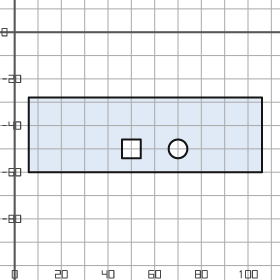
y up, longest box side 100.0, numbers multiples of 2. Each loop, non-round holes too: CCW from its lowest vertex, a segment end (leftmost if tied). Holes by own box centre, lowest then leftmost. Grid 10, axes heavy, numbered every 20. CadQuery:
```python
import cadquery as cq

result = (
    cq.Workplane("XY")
    .moveTo(6.0, -60.0)
    .lineTo(106.0, -60.0)
    .lineTo(106.0, -28.0)
    .lineTo(6.0, -28.0)
    .close()
    .moveTo(46.0, -54.0)
    .lineTo(54.0, -54.0)
    .lineTo(54.0, -46.0)
    .lineTo(46.0, -46.0)
    .close()
    .moveTo(70.0, -50.0)
    .circle(4.0)
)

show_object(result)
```